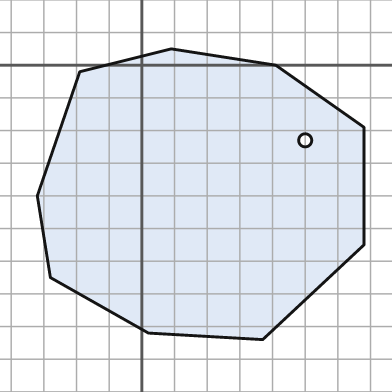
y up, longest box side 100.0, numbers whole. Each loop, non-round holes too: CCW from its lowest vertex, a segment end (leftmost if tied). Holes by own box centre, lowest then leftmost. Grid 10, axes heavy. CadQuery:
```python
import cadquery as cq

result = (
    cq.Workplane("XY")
    .moveTo(37.0, -84.0)
    .lineTo(68.0, -55.0)
    .lineTo(68.0, -19.0)
    .lineTo(41.0, 0.0)
    .lineTo(9.0, 5.0)
    .lineTo(-19.0, -2.0)
    .lineTo(-32.0, -40.0)
    .lineTo(-28.0, -65.0)
    .lineTo(2.0, -82.0)
    .close()
    .moveTo(50.0, -23.0)
    .circle(2.0)
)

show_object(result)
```